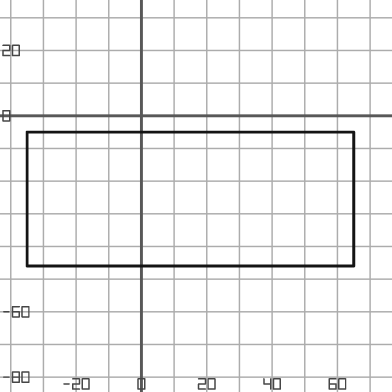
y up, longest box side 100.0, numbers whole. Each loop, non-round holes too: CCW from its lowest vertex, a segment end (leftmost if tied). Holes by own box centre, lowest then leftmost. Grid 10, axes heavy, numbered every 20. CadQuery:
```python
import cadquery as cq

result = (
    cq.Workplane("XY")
    .moveTo(-35.0, -46.0)
    .lineTo(65.0, -46.0)
    .lineTo(65.0, -5.0)
    .lineTo(-35.0, -5.0)
    .close()
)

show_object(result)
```